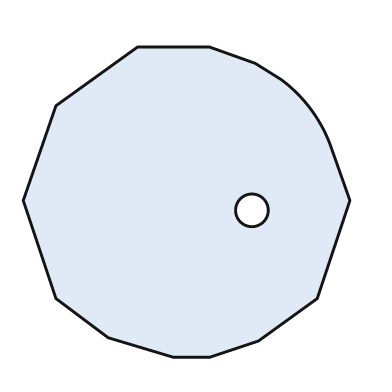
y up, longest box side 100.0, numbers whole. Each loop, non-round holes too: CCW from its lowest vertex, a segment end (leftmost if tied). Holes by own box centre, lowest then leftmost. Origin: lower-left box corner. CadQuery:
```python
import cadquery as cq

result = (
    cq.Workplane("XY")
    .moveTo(46.0, 0.0)
    .lineTo(57.0, 0.0)
    .lineTo(72.0, 5.0)
    .lineTo(90.0, 18.0)
    .lineTo(100.0, 48.0)
    .lineTo(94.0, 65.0)
    .threePointArc((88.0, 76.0), (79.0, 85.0))
    .lineTo(71.0, 90.0)
    .lineTo(57.0, 95.0)
    .lineTo(35.0, 95.0)
    .lineTo(10.0, 77.0)
    .lineTo(0.0, 48.0)
    .lineTo(10.0, 18.0)
    .lineTo(26.0, 6.0)
    .close()
    .moveTo(70.0, 45.0)
    .circle(5.0)
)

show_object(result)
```